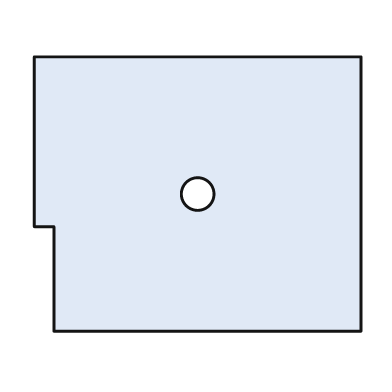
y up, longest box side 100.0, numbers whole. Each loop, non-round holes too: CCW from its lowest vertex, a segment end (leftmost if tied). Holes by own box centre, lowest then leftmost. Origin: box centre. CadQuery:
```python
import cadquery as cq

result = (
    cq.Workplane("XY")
    .moveTo(-44.0, -42.0)
    .lineTo(50.0, -42.0)
    .lineTo(50.0, 42.0)
    .lineTo(-50.0, 42.0)
    .lineTo(-50.0, -10.0)
    .lineTo(-44.0, -10.0)
    .close()
    .moveTo(0.0, 0.0)
    .circle(5.0)
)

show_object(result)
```